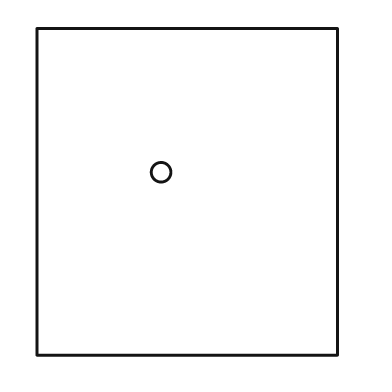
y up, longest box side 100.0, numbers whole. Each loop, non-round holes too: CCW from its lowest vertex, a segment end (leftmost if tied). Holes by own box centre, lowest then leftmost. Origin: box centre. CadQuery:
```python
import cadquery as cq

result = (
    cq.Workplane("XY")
    .moveTo(-46.0, -50.0)
    .lineTo(46.0, -50.0)
    .lineTo(46.0, 50.0)
    .lineTo(-46.0, 50.0)
    .close()
    .moveTo(-8.0, 6.0)
    .circle(3.0)
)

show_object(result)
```